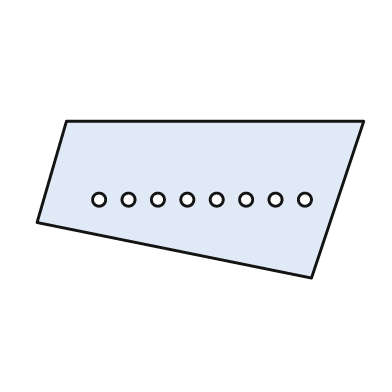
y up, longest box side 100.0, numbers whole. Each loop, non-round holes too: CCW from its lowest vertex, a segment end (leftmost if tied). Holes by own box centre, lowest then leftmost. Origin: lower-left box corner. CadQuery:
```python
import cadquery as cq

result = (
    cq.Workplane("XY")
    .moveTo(84.0, 0.0)
    .lineTo(100.0, 48.0)
    .lineTo(9.0, 48.0)
    .lineTo(0.0, 17.0)
    .close()
    .moveTo(19.0, 24.0)
    .circle(2.0)
    .moveTo(28.0, 24.0)
    .circle(2.0)
    .moveTo(37.0, 24.0)
    .circle(2.0)
    .moveTo(46.0, 24.0)
    .circle(2.0)
    .moveTo(55.0, 24.0)
    .circle(2.0)
    .moveTo(64.0, 24.0)
    .circle(2.0)
    .moveTo(73.0, 24.0)
    .circle(2.0)
    .moveTo(82.0, 24.0)
    .circle(2.0)
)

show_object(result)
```